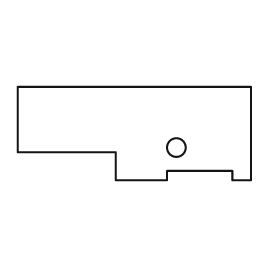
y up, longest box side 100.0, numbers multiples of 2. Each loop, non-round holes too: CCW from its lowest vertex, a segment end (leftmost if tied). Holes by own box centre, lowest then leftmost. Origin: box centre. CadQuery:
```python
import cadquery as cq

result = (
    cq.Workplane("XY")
    .moveTo(-8.0, -20.0)
    .lineTo(14.0, -20.0)
    .lineTo(14.0, -16.0)
    .lineTo(42.0, -16.0)
    .lineTo(42.0, -20.0)
    .lineTo(50.0, -20.0)
    .lineTo(50.0, 20.0)
    .lineTo(-50.0, 20.0)
    .lineTo(-50.0, -8.0)
    .lineTo(-8.0, -8.0)
    .close()
    .moveTo(18.0, -6.0)
    .circle(4.0)
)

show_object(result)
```